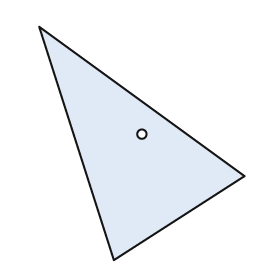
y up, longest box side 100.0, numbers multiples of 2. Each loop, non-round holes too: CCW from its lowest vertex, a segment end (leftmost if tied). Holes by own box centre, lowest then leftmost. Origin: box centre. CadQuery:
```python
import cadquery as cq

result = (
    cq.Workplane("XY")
    .moveTo(-12.0, -50.0)
    .lineTo(44.0, -14.0)
    .lineTo(-44.0, 50.0)
    .close()
    .moveTo(0.0, 4.0)
    .circle(2.0)
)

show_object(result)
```